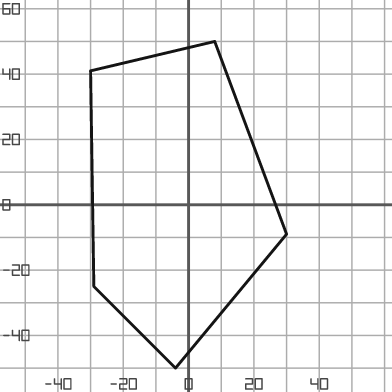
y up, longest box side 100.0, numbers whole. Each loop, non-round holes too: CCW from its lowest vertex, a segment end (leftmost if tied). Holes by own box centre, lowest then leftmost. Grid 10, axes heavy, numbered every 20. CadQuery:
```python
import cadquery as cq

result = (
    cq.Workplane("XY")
    .moveTo(-4.0, -50.0)
    .lineTo(30.0, -9.0)
    .lineTo(8.0, 50.0)
    .lineTo(-30.0, 41.0)
    .lineTo(-29.0, -25.0)
    .close()
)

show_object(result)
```